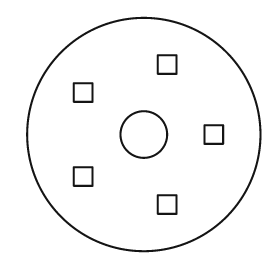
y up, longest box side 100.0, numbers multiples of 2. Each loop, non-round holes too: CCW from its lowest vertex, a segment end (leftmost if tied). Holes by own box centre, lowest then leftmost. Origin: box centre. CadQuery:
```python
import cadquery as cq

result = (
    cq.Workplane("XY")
    .moveTo(0.0, 0.0)
    .circle(50.0)
    .moveTo(6.0, -34.0)
    .lineTo(14.0, -34.0)
    .lineTo(14.0, -26.0)
    .lineTo(6.0, -26.0)
    .close()
    .moveTo(-30.0, -22.0)
    .lineTo(-22.0, -22.0)
    .lineTo(-22.0, -14.0)
    .lineTo(-30.0, -14.0)
    .close()
    .moveTo(0.0, 0.0)
    .circle(10.0)
    .moveTo(26.0, -4.0)
    .lineTo(34.0, -4.0)
    .lineTo(34.0, 4.0)
    .lineTo(26.0, 4.0)
    .close()
    .moveTo(-30.0, 14.0)
    .lineTo(-22.0, 14.0)
    .lineTo(-22.0, 22.0)
    .lineTo(-30.0, 22.0)
    .close()
    .moveTo(6.0, 26.0)
    .lineTo(14.0, 26.0)
    .lineTo(14.0, 34.0)
    .lineTo(6.0, 34.0)
    .close()
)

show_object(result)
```